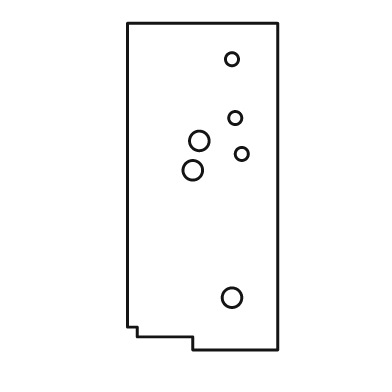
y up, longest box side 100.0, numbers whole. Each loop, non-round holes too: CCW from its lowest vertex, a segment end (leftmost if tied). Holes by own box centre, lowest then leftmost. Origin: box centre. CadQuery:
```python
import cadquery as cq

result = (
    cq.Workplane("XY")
    .moveTo(-3.0, -50.0)
    .lineTo(23.0, -50.0)
    .lineTo(23.0, 50.0)
    .lineTo(-23.0, 50.0)
    .lineTo(-23.0, -43.0)
    .lineTo(-20.0, -43.0)
    .lineTo(-20.0, -46.0)
    .lineTo(-3.0, -46.0)
    .close()
    .moveTo(9.0, -34.0)
    .circle(3.0)
    .moveTo(-3.0, 5.0)
    .circle(3.0)
    .moveTo(12.0, 10.0)
    .circle(2.0)
    .moveTo(-1.0, 14.0)
    .circle(3.0)
    .moveTo(10.0, 21.0)
    .circle(2.0)
    .moveTo(9.0, 39.0)
    .circle(2.0)
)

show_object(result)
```